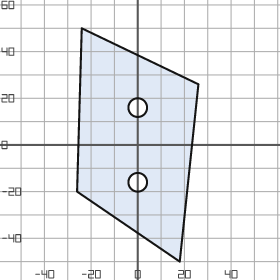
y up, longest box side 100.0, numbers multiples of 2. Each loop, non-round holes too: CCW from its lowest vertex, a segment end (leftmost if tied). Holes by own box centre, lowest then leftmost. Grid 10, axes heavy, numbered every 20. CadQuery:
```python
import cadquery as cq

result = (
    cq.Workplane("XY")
    .moveTo(18.0, -50.0)
    .lineTo(26.0, 26.0)
    .lineTo(-24.0, 50.0)
    .lineTo(-26.0, -20.0)
    .close()
    .moveTo(0.0, -16.0)
    .circle(4.0)
    .moveTo(0.0, 16.0)
    .circle(4.0)
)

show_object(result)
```